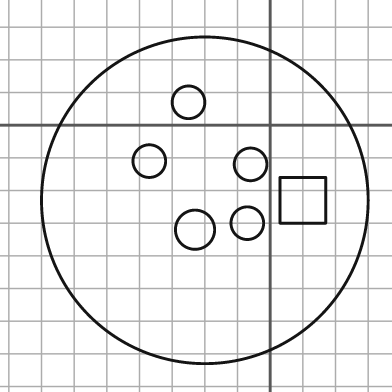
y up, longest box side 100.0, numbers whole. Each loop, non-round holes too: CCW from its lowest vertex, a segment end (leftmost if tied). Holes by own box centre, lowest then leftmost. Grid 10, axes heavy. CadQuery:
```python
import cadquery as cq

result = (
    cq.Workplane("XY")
    .moveTo(-20.0, -23.0)
    .circle(50.0)
    .moveTo(-23.0, -32.0)
    .circle(6.0)
    .moveTo(-7.0, -30.0)
    .circle(5.0)
    .moveTo(3.0, -30.0)
    .lineTo(17.0, -30.0)
    .lineTo(17.0, -16.0)
    .lineTo(3.0, -16.0)
    .close()
    .moveTo(-6.0, -12.0)
    .circle(5.0)
    .moveTo(-37.0, -11.0)
    .circle(5.0)
    .moveTo(-25.0, 7.0)
    .circle(5.0)
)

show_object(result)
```